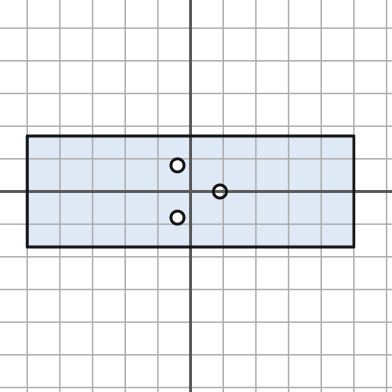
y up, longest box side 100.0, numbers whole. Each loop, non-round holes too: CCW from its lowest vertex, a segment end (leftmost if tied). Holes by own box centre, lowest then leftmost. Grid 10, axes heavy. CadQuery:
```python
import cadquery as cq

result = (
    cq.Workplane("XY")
    .moveTo(-50.0, -17.0)
    .lineTo(50.0, -17.0)
    .lineTo(50.0, 17.0)
    .lineTo(-50.0, 17.0)
    .close()
    .moveTo(-4.0, -8.0)
    .circle(2.0)
    .moveTo(9.0, 0.0)
    .circle(2.0)
    .moveTo(-4.0, 8.0)
    .circle(2.0)
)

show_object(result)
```